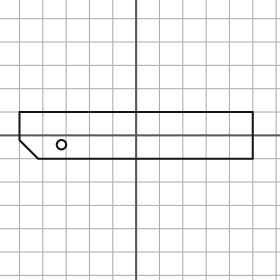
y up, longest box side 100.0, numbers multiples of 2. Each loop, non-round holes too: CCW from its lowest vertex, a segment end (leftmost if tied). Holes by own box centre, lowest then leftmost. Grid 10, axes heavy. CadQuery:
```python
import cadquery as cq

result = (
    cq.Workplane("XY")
    .moveTo(-42.0, -10.0)
    .lineTo(50.0, -10.0)
    .lineTo(50.0, 10.0)
    .lineTo(-50.0, 10.0)
    .lineTo(-50.0, -2.0)
    .close()
    .moveTo(-32.0, -4.0)
    .circle(2.0)
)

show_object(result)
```